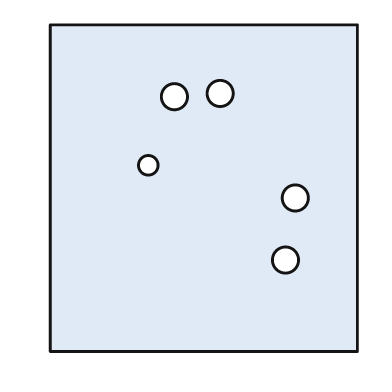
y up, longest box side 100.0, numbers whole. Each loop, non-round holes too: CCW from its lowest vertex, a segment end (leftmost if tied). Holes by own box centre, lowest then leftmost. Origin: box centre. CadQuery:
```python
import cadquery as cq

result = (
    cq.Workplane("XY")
    .moveTo(-47.0, -50.0)
    .lineTo(47.0, -50.0)
    .lineTo(47.0, 50.0)
    .lineTo(-47.0, 50.0)
    .close()
    .moveTo(25.0, -22.0)
    .circle(4.0)
    .moveTo(28.0, -3.0)
    .circle(4.0)
    .moveTo(-17.0, 7.0)
    .circle(3.0)
    .moveTo(-9.0, 28.0)
    .circle(4.0)
    .moveTo(5.0, 29.0)
    .circle(4.0)
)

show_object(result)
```